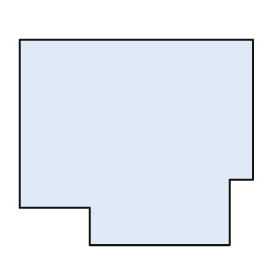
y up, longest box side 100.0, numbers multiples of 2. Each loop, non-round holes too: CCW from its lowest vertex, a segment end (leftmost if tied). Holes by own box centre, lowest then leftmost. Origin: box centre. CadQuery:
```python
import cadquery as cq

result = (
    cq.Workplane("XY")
    .moveTo(-20.0, -44.0)
    .lineTo(40.0, -44.0)
    .lineTo(40.0, -16.0)
    .lineTo(50.0, -16.0)
    .lineTo(50.0, 44.0)
    .lineTo(-50.0, 44.0)
    .lineTo(-50.0, -28.0)
    .lineTo(-20.0, -28.0)
    .close()
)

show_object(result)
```